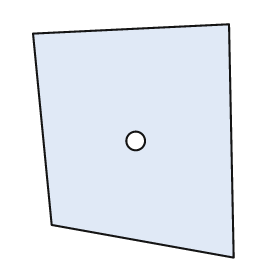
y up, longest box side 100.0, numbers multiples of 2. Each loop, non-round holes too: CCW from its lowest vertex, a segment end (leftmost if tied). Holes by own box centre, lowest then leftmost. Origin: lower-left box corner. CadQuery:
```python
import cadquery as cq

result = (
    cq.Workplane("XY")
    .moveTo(86.0, 0.0)
    .lineTo(84.0, 100.0)
    .lineTo(0.0, 96.0)
    .lineTo(8.0, 14.0)
    .close()
    .moveTo(44.0, 50.0)
    .circle(4.0)
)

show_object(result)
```